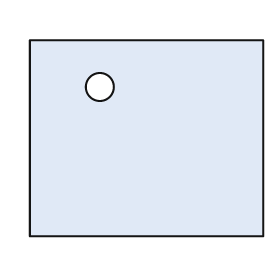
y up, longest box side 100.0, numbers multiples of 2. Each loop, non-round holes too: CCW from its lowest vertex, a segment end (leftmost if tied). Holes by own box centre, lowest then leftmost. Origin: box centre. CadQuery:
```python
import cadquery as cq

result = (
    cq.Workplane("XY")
    .moveTo(-50.0, -42.0)
    .lineTo(50.0, -42.0)
    .lineTo(50.0, 42.0)
    .lineTo(-50.0, 42.0)
    .close()
    .moveTo(-20.0, 22.0)
    .circle(6.0)
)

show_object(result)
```